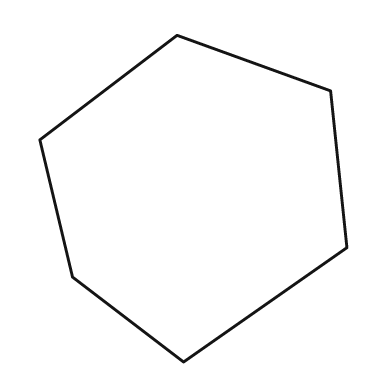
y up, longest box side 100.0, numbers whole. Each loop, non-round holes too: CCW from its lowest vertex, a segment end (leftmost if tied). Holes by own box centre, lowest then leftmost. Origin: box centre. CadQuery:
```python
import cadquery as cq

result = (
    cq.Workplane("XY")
    .moveTo(-3.0, -50.0)
    .lineTo(47.0, -15.0)
    .lineTo(42.0, 33.0)
    .lineTo(-5.0, 50.0)
    .lineTo(-47.0, 18.0)
    .lineTo(-37.0, -24.0)
    .close()
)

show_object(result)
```